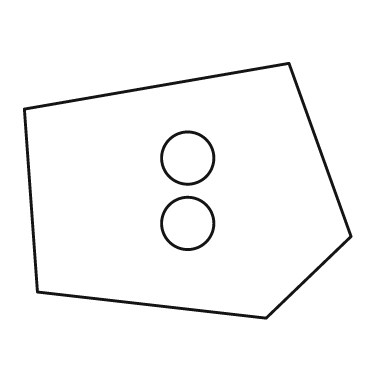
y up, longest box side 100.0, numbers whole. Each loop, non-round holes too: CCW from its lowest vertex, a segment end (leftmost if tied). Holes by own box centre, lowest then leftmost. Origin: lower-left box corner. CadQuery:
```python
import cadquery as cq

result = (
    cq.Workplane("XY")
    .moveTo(74.0, 0.0)
    .lineTo(100.0, 25.0)
    .lineTo(81.0, 78.0)
    .lineTo(0.0, 64.0)
    .lineTo(4.0, 8.0)
    .close()
    .moveTo(50.0, 29.0)
    .circle(8.0)
    .moveTo(50.0, 49.0)
    .circle(8.0)
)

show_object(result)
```